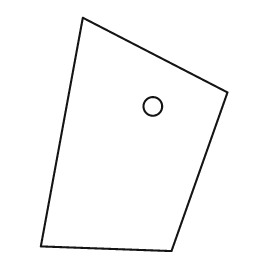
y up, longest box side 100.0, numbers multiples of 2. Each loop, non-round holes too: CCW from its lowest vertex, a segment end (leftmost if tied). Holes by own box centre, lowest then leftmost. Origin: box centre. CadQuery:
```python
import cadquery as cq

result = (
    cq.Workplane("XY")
    .moveTo(16.0, -50.0)
    .lineTo(40.0, 18.0)
    .lineTo(-22.0, 50.0)
    .lineTo(-40.0, -48.0)
    .close()
    .moveTo(8.0, 12.0)
    .circle(4.0)
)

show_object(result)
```